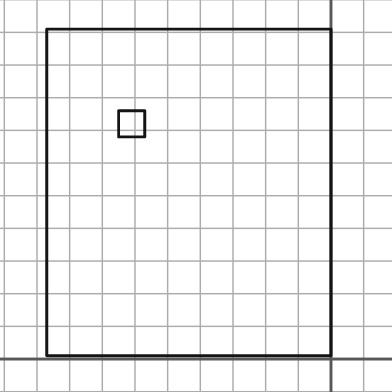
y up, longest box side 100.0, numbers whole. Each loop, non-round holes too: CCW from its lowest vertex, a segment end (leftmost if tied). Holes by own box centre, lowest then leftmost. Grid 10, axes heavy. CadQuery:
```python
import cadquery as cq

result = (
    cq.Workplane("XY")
    .moveTo(-87.0, 1.0)
    .lineTo(0.0, 1.0)
    .lineTo(0.0, 101.0)
    .lineTo(-87.0, 101.0)
    .close()
    .moveTo(-65.0, 68.0)
    .lineTo(-57.0, 68.0)
    .lineTo(-57.0, 76.0)
    .lineTo(-65.0, 76.0)
    .close()
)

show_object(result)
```